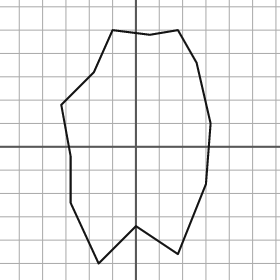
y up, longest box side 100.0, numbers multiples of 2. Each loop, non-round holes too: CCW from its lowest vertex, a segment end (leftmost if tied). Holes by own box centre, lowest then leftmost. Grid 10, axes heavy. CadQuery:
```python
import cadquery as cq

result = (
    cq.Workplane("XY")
    .moveTo(-16.0, -50.0)
    .lineTo(0.0, -34.0)
    .lineTo(18.0, -46.0)
    .lineTo(30.0, -16.0)
    .lineTo(32.0, 10.0)
    .lineTo(26.0, 36.0)
    .lineTo(18.0, 50.0)
    .lineTo(6.0, 48.0)
    .lineTo(-10.0, 50.0)
    .lineTo(-18.0, 32.0)
    .lineTo(-32.0, 18.0)
    .lineTo(-28.0, -4.0)
    .lineTo(-28.0, -24.0)
    .close()
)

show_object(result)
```